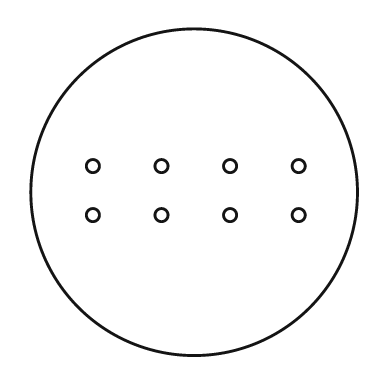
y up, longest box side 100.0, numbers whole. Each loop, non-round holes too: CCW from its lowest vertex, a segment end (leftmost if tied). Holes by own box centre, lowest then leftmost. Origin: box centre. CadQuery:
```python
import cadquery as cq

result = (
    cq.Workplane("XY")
    .moveTo(0.0, 0.0)
    .circle(50.0)
    .moveTo(-31.0, -7.0)
    .circle(2.0)
    .moveTo(-10.0, -7.0)
    .circle(2.0)
    .moveTo(11.0, -7.0)
    .circle(2.0)
    .moveTo(32.0, -7.0)
    .circle(2.0)
    .moveTo(-31.0, 8.0)
    .circle(2.0)
    .moveTo(-10.0, 8.0)
    .circle(2.0)
    .moveTo(11.0, 8.0)
    .circle(2.0)
    .moveTo(32.0, 8.0)
    .circle(2.0)
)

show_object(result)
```